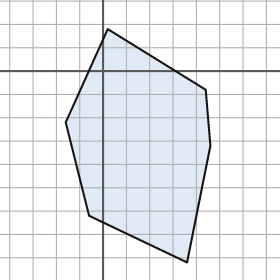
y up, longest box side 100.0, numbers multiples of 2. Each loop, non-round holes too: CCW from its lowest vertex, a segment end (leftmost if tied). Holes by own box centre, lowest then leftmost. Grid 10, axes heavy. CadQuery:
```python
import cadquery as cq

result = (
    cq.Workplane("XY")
    .moveTo(36.0, -82.0)
    .lineTo(46.0, -32.0)
    .lineTo(44.0, -8.0)
    .lineTo(2.0, 18.0)
    .lineTo(-16.0, -22.0)
    .lineTo(-6.0, -62.0)
    .close()
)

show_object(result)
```